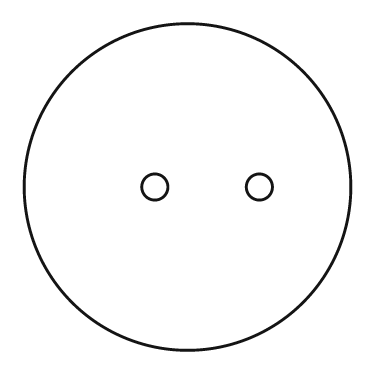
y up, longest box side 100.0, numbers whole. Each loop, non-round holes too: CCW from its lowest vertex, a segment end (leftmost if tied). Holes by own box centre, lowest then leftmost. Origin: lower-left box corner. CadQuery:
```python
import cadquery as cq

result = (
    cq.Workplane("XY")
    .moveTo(50.0, 50.0)
    .circle(50.0)
    .moveTo(40.0, 50.0)
    .circle(4.0)
    .moveTo(72.0, 50.0)
    .circle(4.0)
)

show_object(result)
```